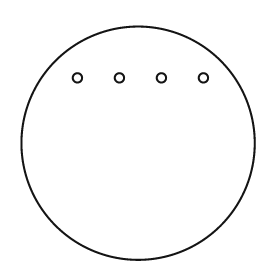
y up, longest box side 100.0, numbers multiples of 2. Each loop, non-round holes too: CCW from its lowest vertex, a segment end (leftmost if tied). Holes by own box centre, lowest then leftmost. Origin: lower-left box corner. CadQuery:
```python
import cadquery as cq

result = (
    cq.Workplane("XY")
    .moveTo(50.0, 50.0)
    .circle(50.0)
    .moveTo(24.0, 78.0)
    .circle(2.0)
    .moveTo(42.0, 78.0)
    .circle(2.0)
    .moveTo(60.0, 78.0)
    .circle(2.0)
    .moveTo(78.0, 78.0)
    .circle(2.0)
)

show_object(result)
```